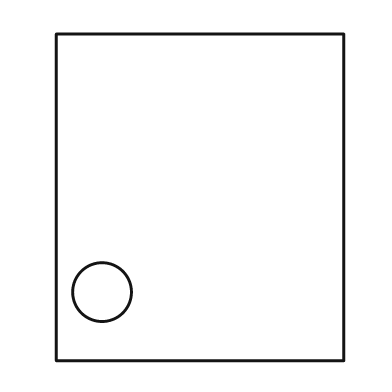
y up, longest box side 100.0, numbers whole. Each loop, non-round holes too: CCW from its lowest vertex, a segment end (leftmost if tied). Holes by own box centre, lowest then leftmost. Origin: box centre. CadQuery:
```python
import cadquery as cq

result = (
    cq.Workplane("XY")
    .moveTo(-44.0, -50.0)
    .lineTo(44.0, -50.0)
    .lineTo(44.0, 50.0)
    .lineTo(-44.0, 50.0)
    .close()
    .moveTo(-30.0, -29.0)
    .circle(9.0)
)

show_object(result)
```